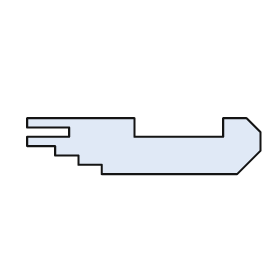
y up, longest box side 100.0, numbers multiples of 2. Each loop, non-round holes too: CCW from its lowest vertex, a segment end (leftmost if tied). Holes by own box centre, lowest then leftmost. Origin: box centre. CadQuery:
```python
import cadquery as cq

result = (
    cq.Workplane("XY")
    .moveTo(-18.0, -12.0)
    .lineTo(40.0, -12.0)
    .lineTo(50.0, -2.0)
    .lineTo(50.0, 6.0)
    .lineTo(44.0, 12.0)
    .lineTo(34.0, 12.0)
    .lineTo(34.0, 4.0)
    .lineTo(-4.0, 4.0)
    .lineTo(-4.0, 12.0)
    .lineTo(-50.0, 12.0)
    .lineTo(-50.0, 8.0)
    .lineTo(-32.0, 8.0)
    .lineTo(-32.0, 4.0)
    .lineTo(-50.0, 4.0)
    .lineTo(-50.0, 0.0)
    .lineTo(-38.0, 0.0)
    .lineTo(-38.0, -4.0)
    .lineTo(-28.0, -4.0)
    .lineTo(-28.0, -8.0)
    .lineTo(-18.0, -8.0)
    .close()
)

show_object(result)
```